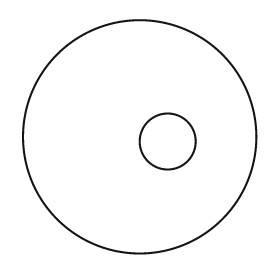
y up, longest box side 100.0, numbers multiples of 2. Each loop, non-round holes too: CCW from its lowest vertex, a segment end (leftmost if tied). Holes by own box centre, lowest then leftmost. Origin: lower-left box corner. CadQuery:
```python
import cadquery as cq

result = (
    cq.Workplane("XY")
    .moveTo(50.0, 50.0)
    .circle(50.0)
    .moveTo(62.0, 48.0)
    .circle(12.0)
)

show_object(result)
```